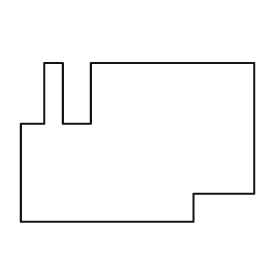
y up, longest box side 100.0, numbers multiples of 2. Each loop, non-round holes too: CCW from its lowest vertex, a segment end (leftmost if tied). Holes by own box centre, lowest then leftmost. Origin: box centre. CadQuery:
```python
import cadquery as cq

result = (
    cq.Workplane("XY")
    .moveTo(-50.0, -34.0)
    .lineTo(24.0, -34.0)
    .lineTo(24.0, -22.0)
    .lineTo(50.0, -22.0)
    .lineTo(50.0, 34.0)
    .lineTo(-20.0, 34.0)
    .lineTo(-20.0, 8.0)
    .lineTo(-32.0, 8.0)
    .lineTo(-32.0, 34.0)
    .lineTo(-40.0, 34.0)
    .lineTo(-40.0, 8.0)
    .lineTo(-50.0, 8.0)
    .close()
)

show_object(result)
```